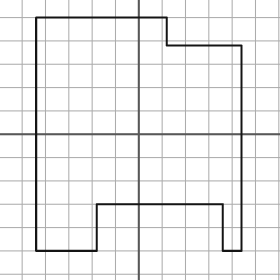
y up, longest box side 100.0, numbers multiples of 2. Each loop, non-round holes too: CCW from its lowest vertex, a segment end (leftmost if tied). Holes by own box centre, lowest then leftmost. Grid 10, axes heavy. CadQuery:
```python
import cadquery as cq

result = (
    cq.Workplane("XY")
    .moveTo(-44.0, -50.0)
    .lineTo(-18.0, -50.0)
    .lineTo(-18.0, -30.0)
    .lineTo(36.0, -30.0)
    .lineTo(36.0, -50.0)
    .lineTo(44.0, -50.0)
    .lineTo(44.0, 38.0)
    .lineTo(12.0, 38.0)
    .lineTo(12.0, 50.0)
    .lineTo(-44.0, 50.0)
    .close()
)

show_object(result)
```